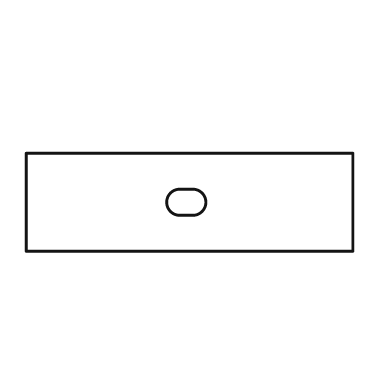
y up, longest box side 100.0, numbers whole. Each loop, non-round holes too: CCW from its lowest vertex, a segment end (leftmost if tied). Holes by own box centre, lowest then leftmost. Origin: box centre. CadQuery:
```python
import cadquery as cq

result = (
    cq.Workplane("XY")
    .moveTo(-50.0, -15.0)
    .lineTo(50.0, -15.0)
    .lineTo(50.0, 15.0)
    .lineTo(-50.0, 15.0)
    .close()
    .moveTo(-3.0, -4.0)
    .lineTo(1.0, -4.0)
    .threePointArc((5.0, 0.0), (1.0, 4.0))
    .lineTo(-3.0, 4.0)
    .threePointArc((-7.0, 0.0), (-3.0, -4.0))
    .close()
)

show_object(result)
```